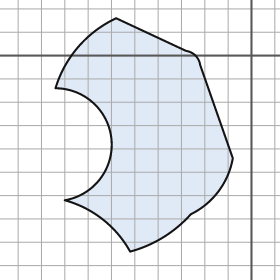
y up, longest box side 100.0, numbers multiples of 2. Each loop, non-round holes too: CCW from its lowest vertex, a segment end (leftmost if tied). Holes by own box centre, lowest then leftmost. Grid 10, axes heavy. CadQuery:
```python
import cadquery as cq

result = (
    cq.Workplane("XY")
    .moveTo(-52.0, -84.0)
    .threePointArc((-38.0, -78.0), (-26.0, -68.0))
    .threePointArc((-14.0, -58.0), (-8.0, -44.0))
    .lineTo(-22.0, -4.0)
    .threePointArc((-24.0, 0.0), (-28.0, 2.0))
    .lineTo(-58.0, 16.0)
    .threePointArc((-74.0, 4.0), (-84.0, -14.0))
    .threePointArc((-60.0, -36.0), (-80.0, -62.0))
    .threePointArc((-64.0, -70.0), (-52.0, -84.0))
    .close()
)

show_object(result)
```